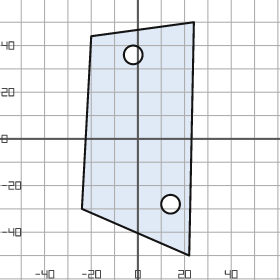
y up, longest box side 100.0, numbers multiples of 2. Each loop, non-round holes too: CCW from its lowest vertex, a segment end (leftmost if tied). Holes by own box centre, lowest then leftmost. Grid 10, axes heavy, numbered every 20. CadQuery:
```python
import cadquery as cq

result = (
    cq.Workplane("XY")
    .moveTo(22.0, -50.0)
    .lineTo(24.0, 50.0)
    .lineTo(-20.0, 44.0)
    .lineTo(-24.0, -30.0)
    .close()
    .moveTo(14.0, -28.0)
    .circle(4.0)
    .moveTo(-2.0, 36.0)
    .circle(4.0)
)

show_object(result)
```